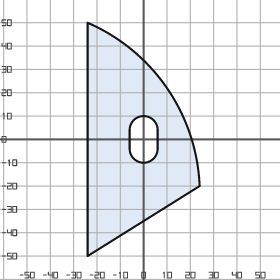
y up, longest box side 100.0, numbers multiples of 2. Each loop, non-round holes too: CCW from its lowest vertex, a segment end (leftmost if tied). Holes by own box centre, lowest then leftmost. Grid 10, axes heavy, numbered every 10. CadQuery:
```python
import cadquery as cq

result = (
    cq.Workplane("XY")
    .moveTo(-24.0, -50.0)
    .lineTo(24.0, -20.0)
    .threePointArc((10.0, 22.0), (-24.0, 50.0))
    .close()
    .moveTo(-6.0, -4.0)
    .threePointArc((0.0, -10.0), (6.0, -4.0))
    .lineTo(6.0, 4.0)
    .threePointArc((0.0, 10.0), (-6.0, 4.0))
    .close()
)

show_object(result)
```